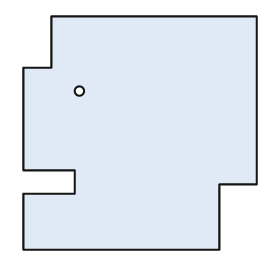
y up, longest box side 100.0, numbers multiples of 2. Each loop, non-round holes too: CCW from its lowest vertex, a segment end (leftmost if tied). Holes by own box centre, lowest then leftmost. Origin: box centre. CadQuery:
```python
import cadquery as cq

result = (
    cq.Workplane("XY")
    .moveTo(-50.0, -50.0)
    .lineTo(34.0, -50.0)
    .lineTo(34.0, -22.0)
    .lineTo(50.0, -22.0)
    .lineTo(50.0, 50.0)
    .lineTo(-38.0, 50.0)
    .lineTo(-38.0, 28.0)
    .lineTo(-50.0, 28.0)
    .lineTo(-50.0, -16.0)
    .lineTo(-28.0, -16.0)
    .lineTo(-28.0, -26.0)
    .lineTo(-50.0, -26.0)
    .close()
    .moveTo(-26.0, 18.0)
    .circle(2.0)
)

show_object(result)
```